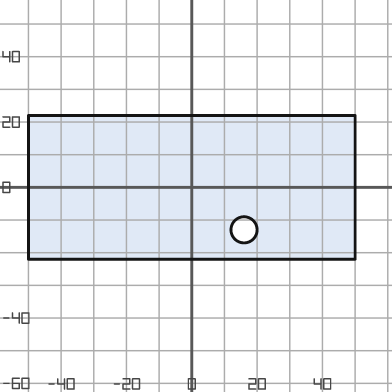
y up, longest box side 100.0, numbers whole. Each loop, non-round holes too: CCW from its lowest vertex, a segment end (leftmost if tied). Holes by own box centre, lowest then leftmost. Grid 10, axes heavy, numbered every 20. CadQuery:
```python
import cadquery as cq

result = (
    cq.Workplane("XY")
    .moveTo(-50.0, -22.0)
    .lineTo(50.0, -22.0)
    .lineTo(50.0, 22.0)
    .lineTo(-50.0, 22.0)
    .close()
    .moveTo(16.0, -13.0)
    .circle(4.0)
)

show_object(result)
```